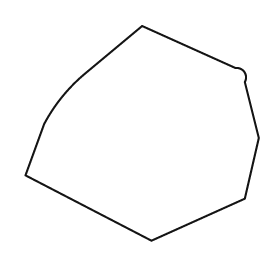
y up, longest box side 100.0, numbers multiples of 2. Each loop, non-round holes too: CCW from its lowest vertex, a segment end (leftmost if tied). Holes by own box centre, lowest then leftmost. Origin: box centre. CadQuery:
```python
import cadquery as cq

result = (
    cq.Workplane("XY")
    .moveTo(4.0, -46.0)
    .lineTo(44.0, -28.0)
    .lineTo(50.0, -2.0)
    .lineTo(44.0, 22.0)
    .threePointArc((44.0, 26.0), (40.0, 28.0))
    .lineTo(0.0, 46.0)
    .lineTo(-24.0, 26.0)
    .threePointArc((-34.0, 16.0), (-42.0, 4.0))
    .lineTo(-50.0, -18.0)
    .close()
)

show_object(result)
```